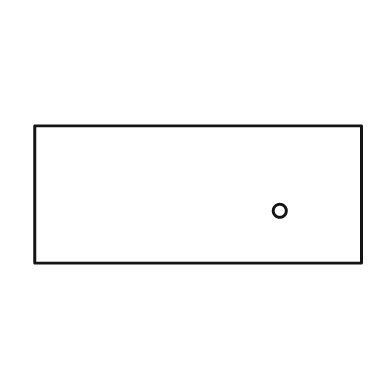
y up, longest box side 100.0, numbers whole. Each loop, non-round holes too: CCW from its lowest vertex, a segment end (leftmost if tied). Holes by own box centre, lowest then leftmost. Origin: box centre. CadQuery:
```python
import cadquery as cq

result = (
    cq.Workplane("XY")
    .moveTo(-50.0, -21.0)
    .lineTo(50.0, -21.0)
    .lineTo(50.0, 21.0)
    .lineTo(-50.0, 21.0)
    .close()
    .moveTo(25.0, -5.0)
    .circle(2.0)
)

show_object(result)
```